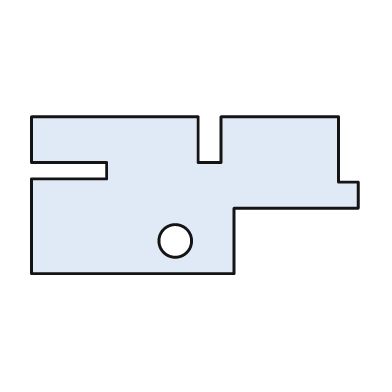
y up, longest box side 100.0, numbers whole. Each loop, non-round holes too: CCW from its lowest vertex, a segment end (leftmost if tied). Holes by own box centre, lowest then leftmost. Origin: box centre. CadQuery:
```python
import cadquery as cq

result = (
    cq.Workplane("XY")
    .moveTo(-50.0, -24.0)
    .lineTo(12.0, -24.0)
    .lineTo(12.0, -4.0)
    .lineTo(50.0, -4.0)
    .lineTo(50.0, 4.0)
    .lineTo(44.0, 4.0)
    .lineTo(44.0, 24.0)
    .lineTo(8.0, 24.0)
    .lineTo(8.0, 10.0)
    .lineTo(1.0, 10.0)
    .lineTo(1.0, 24.0)
    .lineTo(-50.0, 24.0)
    .lineTo(-50.0, 10.0)
    .lineTo(-27.0, 10.0)
    .lineTo(-27.0, 5.0)
    .lineTo(-50.0, 5.0)
    .close()
    .moveTo(-6.0, -14.0)
    .circle(5.0)
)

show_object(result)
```